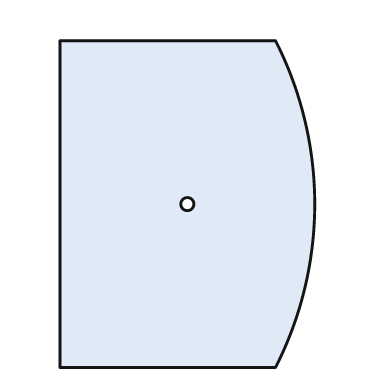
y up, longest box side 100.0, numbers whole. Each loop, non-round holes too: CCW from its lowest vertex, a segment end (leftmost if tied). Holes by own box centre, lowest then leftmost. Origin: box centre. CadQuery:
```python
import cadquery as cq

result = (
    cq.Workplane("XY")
    .moveTo(-39.0, -50.0)
    .lineTo(27.0, -50.0)
    .threePointArc((39.0, 0.0), (27.0, 50.0))
    .lineTo(-39.0, 50.0)
    .close()
    .moveTo(0.0, 0.0)
    .circle(2.0)
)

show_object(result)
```